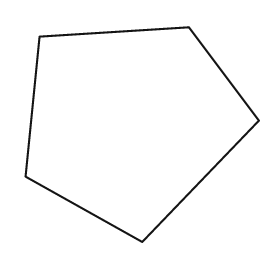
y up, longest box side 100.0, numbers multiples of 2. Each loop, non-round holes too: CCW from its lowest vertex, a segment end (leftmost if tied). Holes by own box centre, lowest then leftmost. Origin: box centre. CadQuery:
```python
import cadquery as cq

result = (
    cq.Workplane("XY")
    .moveTo(0.0, -46.0)
    .lineTo(50.0, 6.0)
    .lineTo(20.0, 46.0)
    .lineTo(-44.0, 42.0)
    .lineTo(-50.0, -18.0)
    .close()
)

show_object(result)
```